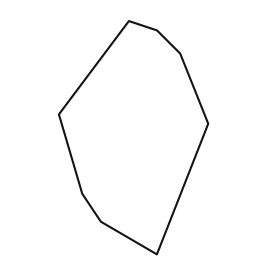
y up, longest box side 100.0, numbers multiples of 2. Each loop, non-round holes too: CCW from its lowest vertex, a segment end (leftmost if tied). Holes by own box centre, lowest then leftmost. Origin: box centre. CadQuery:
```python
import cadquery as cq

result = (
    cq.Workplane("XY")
    .moveTo(10.0, -50.0)
    .lineTo(32.0, 6.0)
    .lineTo(20.0, 36.0)
    .lineTo(10.0, 46.0)
    .lineTo(-2.0, 50.0)
    .lineTo(-32.0, 10.0)
    .lineTo(-22.0, -24.0)
    .lineTo(-14.0, -36.0)
    .close()
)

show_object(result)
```